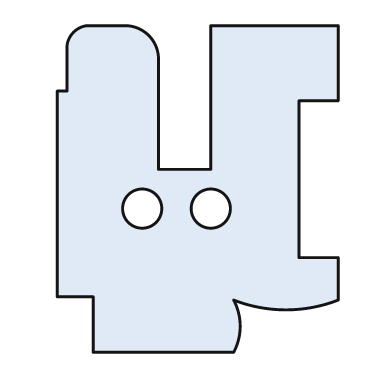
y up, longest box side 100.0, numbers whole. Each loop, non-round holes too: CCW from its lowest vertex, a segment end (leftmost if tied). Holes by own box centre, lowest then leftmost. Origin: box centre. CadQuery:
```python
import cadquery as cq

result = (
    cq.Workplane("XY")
    .moveTo(-32.0, -50.0)
    .lineTo(11.0, -50.0)
    .threePointArc((13.0, -42.0), (11.0, -34.0))
    .threePointArc((27.0, -37.0), (43.0, -34.0))
    .lineTo(43.0, -21.0)
    .lineTo(31.0, -21.0)
    .lineTo(31.0, 27.0)
    .lineTo(43.0, 27.0)
    .lineTo(43.0, 50.0)
    .lineTo(4.0, 50.0)
    .lineTo(4.0, 6.0)
    .lineTo(-12.0, 6.0)
    .lineTo(-12.0, 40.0)
    .threePointArc((-15.0, 47.0), (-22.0, 50.0))
    .lineTo(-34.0, 50.0)
    .threePointArc((-38.0, 48.0), (-40.0, 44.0))
    .lineTo(-40.0, 30.0)
    .lineTo(-43.0, 30.0)
    .lineTo(-43.0, -33.0)
    .lineTo(-32.0, -33.0)
    .close()
    .moveTo(-17.0, -6.0)
    .circle(6.0)
    .moveTo(4.0, -6.0)
    .circle(6.0)
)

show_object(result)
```